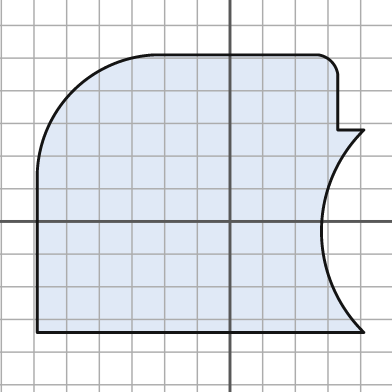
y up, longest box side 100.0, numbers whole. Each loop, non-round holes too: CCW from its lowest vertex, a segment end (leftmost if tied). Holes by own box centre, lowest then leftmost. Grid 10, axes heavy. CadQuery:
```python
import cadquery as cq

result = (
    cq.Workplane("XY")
    .moveTo(-59.0, -34.0)
    .lineTo(41.0, -34.0)
    .threePointArc((28.0, -3.0), (41.0, 28.0))
    .lineTo(33.0, 28.0)
    .lineTo(33.0, 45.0)
    .threePointArc((31.0, 49.0), (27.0, 51.0))
    .lineTo(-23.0, 51.0)
    .threePointArc((-48.0, 40.0), (-59.0, 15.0))
    .close()
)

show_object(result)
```